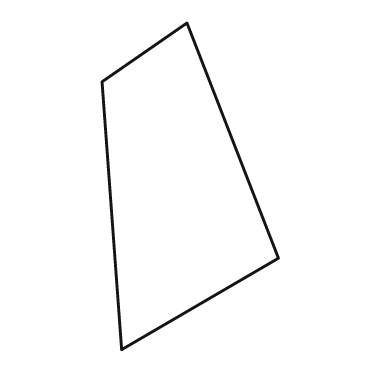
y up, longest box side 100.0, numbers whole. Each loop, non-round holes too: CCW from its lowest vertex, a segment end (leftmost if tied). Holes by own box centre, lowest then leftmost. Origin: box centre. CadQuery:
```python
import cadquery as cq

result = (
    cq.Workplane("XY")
    .moveTo(-21.0, -50.0)
    .lineTo(27.0, -22.0)
    .lineTo(-1.0, 50.0)
    .lineTo(-27.0, 32.0)
    .close()
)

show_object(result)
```